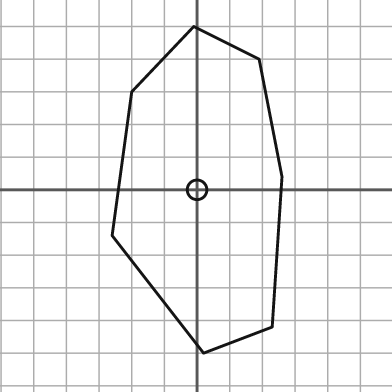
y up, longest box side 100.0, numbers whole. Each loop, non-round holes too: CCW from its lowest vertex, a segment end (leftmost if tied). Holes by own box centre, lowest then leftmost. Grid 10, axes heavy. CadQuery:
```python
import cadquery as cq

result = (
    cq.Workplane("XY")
    .moveTo(2.0, -50.0)
    .lineTo(23.0, -42.0)
    .lineTo(26.0, 4.0)
    .lineTo(19.0, 40.0)
    .lineTo(-1.0, 50.0)
    .lineTo(-20.0, 30.0)
    .lineTo(-26.0, -14.0)
    .close()
    .moveTo(0.0, 0.0)
    .circle(3.0)
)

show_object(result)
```